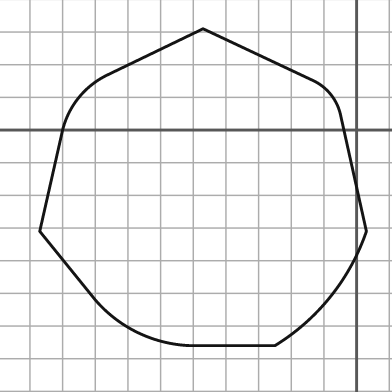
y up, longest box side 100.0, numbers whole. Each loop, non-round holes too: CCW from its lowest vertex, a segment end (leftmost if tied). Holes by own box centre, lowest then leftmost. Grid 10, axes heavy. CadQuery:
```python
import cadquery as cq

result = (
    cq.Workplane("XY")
    .moveTo(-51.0, -66.0)
    .lineTo(-25.0, -66.0)
    .threePointArc((-8.0, -51.0), (3.0, -31.0))
    .lineTo(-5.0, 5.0)
    .threePointArc((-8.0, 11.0), (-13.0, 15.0))
    .lineTo(-47.0, 31.0)
    .lineTo(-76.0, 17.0)
    .threePointArc((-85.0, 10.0), (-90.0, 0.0))
    .lineTo(-97.0, -31.0)
    .lineTo(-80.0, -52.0)
    .threePointArc((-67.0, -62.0), (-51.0, -66.0))
    .close()
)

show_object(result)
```